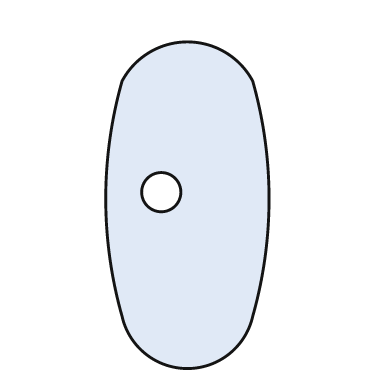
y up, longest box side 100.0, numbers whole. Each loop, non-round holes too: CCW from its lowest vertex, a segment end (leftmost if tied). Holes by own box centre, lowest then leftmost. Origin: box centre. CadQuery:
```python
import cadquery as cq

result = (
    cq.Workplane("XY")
    .moveTo(-20.0, -34.0)
    .threePointArc((0.0, -50.0), (20.0, -34.0))
    .threePointArc((25.0, 2.0), (20.0, 38.0))
    .threePointArc((0.0, 50.0), (-20.0, 38.0))
    .threePointArc((-25.0, 2.0), (-20.0, -34.0))
    .close()
    .moveTo(-8.0, 4.0)
    .circle(6.0)
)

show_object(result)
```